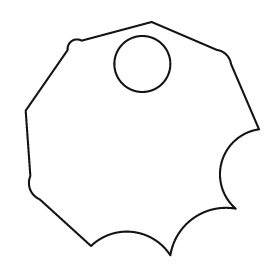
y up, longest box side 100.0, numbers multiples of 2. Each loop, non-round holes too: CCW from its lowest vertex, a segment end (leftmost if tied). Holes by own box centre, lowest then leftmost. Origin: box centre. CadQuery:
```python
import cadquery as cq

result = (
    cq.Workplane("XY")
    .moveTo(12.0, -50.0)
    .threePointArc((22.0, -34.0), (40.0, -30.0))
    .threePointArc((34.0, -10.0), (50.0, 4.0))
    .lineTo(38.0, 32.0)
    .threePointArc((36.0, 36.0), (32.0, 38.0))
    .lineTo(4.0, 50.0)
    .lineTo(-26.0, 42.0)
    .threePointArc((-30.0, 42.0), (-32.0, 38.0))
    .lineTo(-50.0, 12.0)
    .lineTo(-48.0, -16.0)
    .threePointArc((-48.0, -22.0), (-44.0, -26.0))
    .lineTo(-22.0, -46.0)
    .threePointArc((-4.0, -40.0), (12.0, -50.0))
    .close()
    .moveTo(0.0, 32.0)
    .circle(12.0)
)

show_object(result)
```